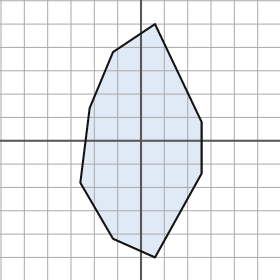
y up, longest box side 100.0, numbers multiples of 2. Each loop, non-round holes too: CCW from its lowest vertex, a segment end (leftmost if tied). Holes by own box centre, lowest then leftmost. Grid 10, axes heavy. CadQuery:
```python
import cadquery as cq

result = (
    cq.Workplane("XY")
    .moveTo(6.0, -50.0)
    .lineTo(26.0, -14.0)
    .lineTo(26.0, 8.0)
    .lineTo(6.0, 50.0)
    .lineTo(-12.0, 38.0)
    .lineTo(-22.0, 14.0)
    .lineTo(-26.0, -18.0)
    .lineTo(-12.0, -42.0)
    .close()
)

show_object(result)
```